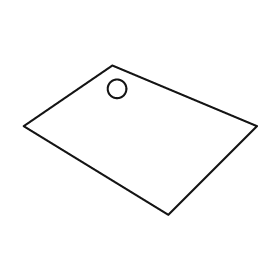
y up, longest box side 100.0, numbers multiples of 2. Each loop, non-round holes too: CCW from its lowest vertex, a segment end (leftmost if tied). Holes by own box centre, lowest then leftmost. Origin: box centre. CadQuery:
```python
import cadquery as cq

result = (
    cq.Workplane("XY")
    .moveTo(12.0, -32.0)
    .lineTo(50.0, 6.0)
    .lineTo(-12.0, 32.0)
    .lineTo(-50.0, 6.0)
    .close()
    .moveTo(-10.0, 22.0)
    .circle(4.0)
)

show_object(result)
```